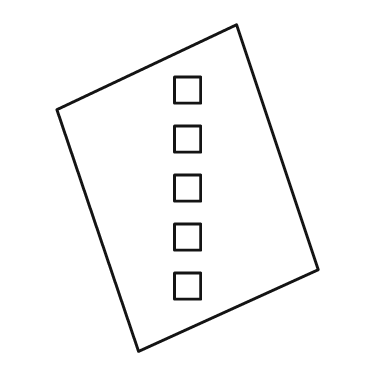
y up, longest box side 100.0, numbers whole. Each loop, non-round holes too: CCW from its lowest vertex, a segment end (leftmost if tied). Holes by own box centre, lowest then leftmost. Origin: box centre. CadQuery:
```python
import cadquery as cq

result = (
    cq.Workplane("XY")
    .moveTo(-15.0, -50.0)
    .lineTo(40.0, -25.0)
    .lineTo(15.0, 50.0)
    .lineTo(-40.0, 24.0)
    .close()
    .moveTo(-4.0, -34.0)
    .lineTo(4.0, -34.0)
    .lineTo(4.0, -26.0)
    .lineTo(-4.0, -26.0)
    .close()
    .moveTo(-4.0, -19.0)
    .lineTo(4.0, -19.0)
    .lineTo(4.0, -11.0)
    .lineTo(-4.0, -11.0)
    .close()
    .moveTo(-4.0, -4.0)
    .lineTo(4.0, -4.0)
    .lineTo(4.0, 4.0)
    .lineTo(-4.0, 4.0)
    .close()
    .moveTo(-4.0, 11.0)
    .lineTo(4.0, 11.0)
    .lineTo(4.0, 19.0)
    .lineTo(-4.0, 19.0)
    .close()
    .moveTo(-4.0, 26.0)
    .lineTo(4.0, 26.0)
    .lineTo(4.0, 34.0)
    .lineTo(-4.0, 34.0)
    .close()
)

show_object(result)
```